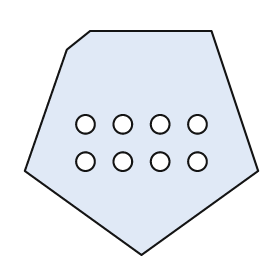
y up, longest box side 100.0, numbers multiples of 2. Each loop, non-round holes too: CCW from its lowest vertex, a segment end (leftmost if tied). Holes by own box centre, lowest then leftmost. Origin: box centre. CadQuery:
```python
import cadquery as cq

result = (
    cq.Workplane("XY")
    .moveTo(0.0, -48.0)
    .lineTo(50.0, -12.0)
    .lineTo(30.0, 48.0)
    .lineTo(-22.0, 48.0)
    .lineTo(-32.0, 40.0)
    .lineTo(-50.0, -12.0)
    .close()
    .moveTo(-24.0, -8.0)
    .circle(4.0)
    .moveTo(-8.0, -8.0)
    .circle(4.0)
    .moveTo(8.0, -8.0)
    .circle(4.0)
    .moveTo(24.0, -8.0)
    .circle(4.0)
    .moveTo(-24.0, 8.0)
    .circle(4.0)
    .moveTo(-8.0, 8.0)
    .circle(4.0)
    .moveTo(8.0, 8.0)
    .circle(4.0)
    .moveTo(24.0, 8.0)
    .circle(4.0)
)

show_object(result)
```